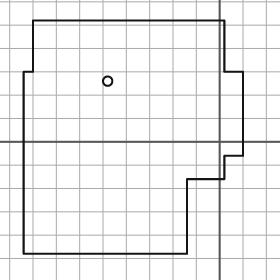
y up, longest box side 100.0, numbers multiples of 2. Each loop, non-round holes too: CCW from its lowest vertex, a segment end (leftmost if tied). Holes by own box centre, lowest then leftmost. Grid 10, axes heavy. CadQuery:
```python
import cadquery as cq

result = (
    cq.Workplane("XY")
    .moveTo(-84.0, -48.0)
    .lineTo(-14.0, -48.0)
    .lineTo(-14.0, -16.0)
    .lineTo(2.0, -16.0)
    .lineTo(2.0, -6.0)
    .lineTo(10.0, -6.0)
    .lineTo(10.0, 30.0)
    .lineTo(2.0, 30.0)
    .lineTo(2.0, 52.0)
    .lineTo(-80.0, 52.0)
    .lineTo(-80.0, 30.0)
    .lineTo(-84.0, 30.0)
    .close()
    .moveTo(-48.0, 26.0)
    .circle(2.0)
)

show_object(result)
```